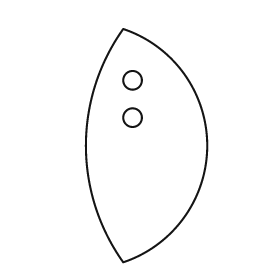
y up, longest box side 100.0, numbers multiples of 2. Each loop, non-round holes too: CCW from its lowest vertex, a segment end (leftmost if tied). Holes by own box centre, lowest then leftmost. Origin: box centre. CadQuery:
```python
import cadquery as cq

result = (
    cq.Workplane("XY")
    .moveTo(-10.0, -50.0)
    .threePointArc((26.0, 0.0), (-10.0, 50.0))
    .threePointArc((-26.0, 0.0), (-10.0, -50.0))
    .close()
    .moveTo(-6.0, 12.0)
    .circle(4.0)
    .moveTo(-6.0, 28.0)
    .circle(4.0)
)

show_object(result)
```